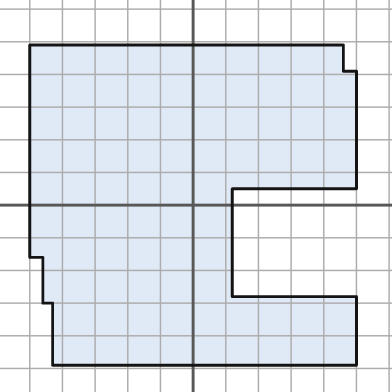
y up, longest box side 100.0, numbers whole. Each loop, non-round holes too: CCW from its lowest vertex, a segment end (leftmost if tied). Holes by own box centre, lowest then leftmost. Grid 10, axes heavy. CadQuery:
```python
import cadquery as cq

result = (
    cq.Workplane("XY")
    .moveTo(-43.0, -49.0)
    .lineTo(50.0, -49.0)
    .lineTo(50.0, -28.0)
    .lineTo(12.0, -28.0)
    .lineTo(12.0, 5.0)
    .lineTo(50.0, 5.0)
    .lineTo(50.0, 41.0)
    .lineTo(46.0, 41.0)
    .lineTo(46.0, 49.0)
    .lineTo(-50.0, 49.0)
    .lineTo(-50.0, -16.0)
    .lineTo(-46.0, -16.0)
    .lineTo(-46.0, -30.0)
    .lineTo(-43.0, -30.0)
    .close()
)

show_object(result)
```